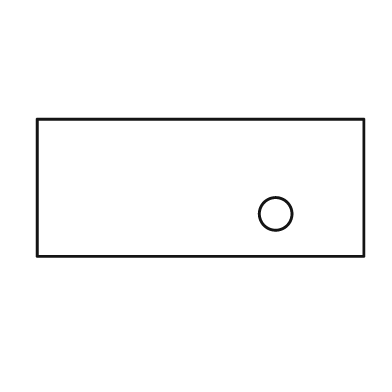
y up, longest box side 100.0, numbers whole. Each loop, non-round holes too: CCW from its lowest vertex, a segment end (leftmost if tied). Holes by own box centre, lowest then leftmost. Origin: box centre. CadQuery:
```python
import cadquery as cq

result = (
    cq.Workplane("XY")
    .moveTo(-50.0, -21.0)
    .lineTo(50.0, -21.0)
    .lineTo(50.0, 21.0)
    .lineTo(-50.0, 21.0)
    .close()
    .moveTo(23.0, -8.0)
    .circle(5.0)
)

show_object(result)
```